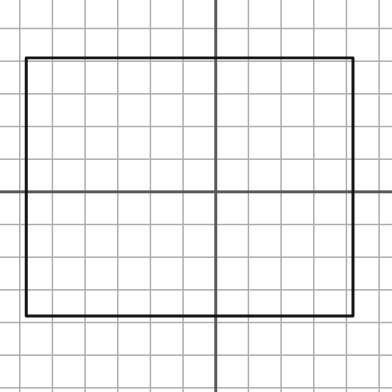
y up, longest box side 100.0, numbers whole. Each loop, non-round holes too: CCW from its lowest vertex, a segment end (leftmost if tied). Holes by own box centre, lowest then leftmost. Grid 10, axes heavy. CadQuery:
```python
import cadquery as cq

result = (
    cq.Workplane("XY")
    .moveTo(-58.0, -38.0)
    .lineTo(42.0, -38.0)
    .lineTo(42.0, 41.0)
    .lineTo(-58.0, 41.0)
    .close()
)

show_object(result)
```